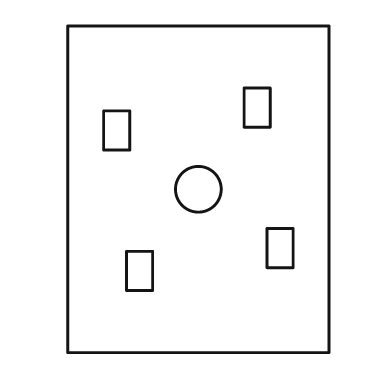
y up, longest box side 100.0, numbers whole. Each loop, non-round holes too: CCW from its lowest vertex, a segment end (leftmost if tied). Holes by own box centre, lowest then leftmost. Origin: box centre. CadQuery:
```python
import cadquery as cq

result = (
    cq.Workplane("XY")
    .moveTo(-40.0, -50.0)
    .lineTo(40.0, -50.0)
    .lineTo(40.0, 50.0)
    .lineTo(-40.0, 50.0)
    .close()
    .moveTo(-22.0, -31.0)
    .lineTo(-14.0, -31.0)
    .lineTo(-14.0, -19.0)
    .lineTo(-22.0, -19.0)
    .close()
    .moveTo(21.0, -24.0)
    .lineTo(29.0, -24.0)
    .lineTo(29.0, -12.0)
    .lineTo(21.0, -12.0)
    .close()
    .moveTo(0.0, 0.0)
    .circle(7.0)
    .moveTo(-29.0, 12.0)
    .lineTo(-21.0, 12.0)
    .lineTo(-21.0, 24.0)
    .lineTo(-29.0, 24.0)
    .close()
    .moveTo(14.0, 19.0)
    .lineTo(22.0, 19.0)
    .lineTo(22.0, 31.0)
    .lineTo(14.0, 31.0)
    .close()
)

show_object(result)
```